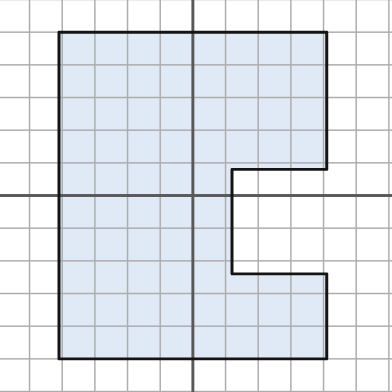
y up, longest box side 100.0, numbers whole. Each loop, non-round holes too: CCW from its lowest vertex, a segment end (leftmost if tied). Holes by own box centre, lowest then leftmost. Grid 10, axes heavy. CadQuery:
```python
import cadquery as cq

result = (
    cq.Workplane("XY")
    .moveTo(-41.0, -50.0)
    .lineTo(41.0, -50.0)
    .lineTo(41.0, -24.0)
    .lineTo(12.0, -24.0)
    .lineTo(12.0, 8.0)
    .lineTo(41.0, 8.0)
    .lineTo(41.0, 50.0)
    .lineTo(-41.0, 50.0)
    .close()
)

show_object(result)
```